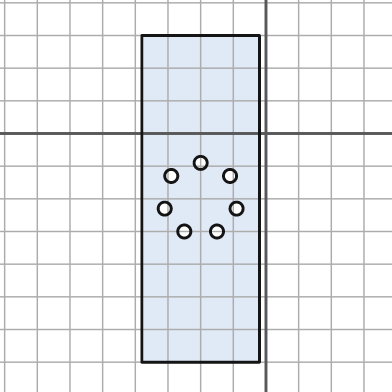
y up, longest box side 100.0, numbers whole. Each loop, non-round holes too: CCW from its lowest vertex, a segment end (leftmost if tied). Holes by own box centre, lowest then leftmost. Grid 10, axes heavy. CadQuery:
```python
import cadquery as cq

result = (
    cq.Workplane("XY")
    .moveTo(-38.0, -70.0)
    .lineTo(-2.0, -70.0)
    .lineTo(-2.0, 30.0)
    .lineTo(-38.0, 30.0)
    .close()
    .moveTo(-25.0, -30.0)
    .circle(2.0)
    .moveTo(-15.0, -30.0)
    .circle(2.0)
    .moveTo(-31.0, -23.0)
    .circle(2.0)
    .moveTo(-9.0, -23.0)
    .circle(2.0)
    .moveTo(-29.0, -13.0)
    .circle(2.0)
    .moveTo(-11.0, -13.0)
    .circle(2.0)
    .moveTo(-20.0, -9.0)
    .circle(2.0)
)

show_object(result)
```